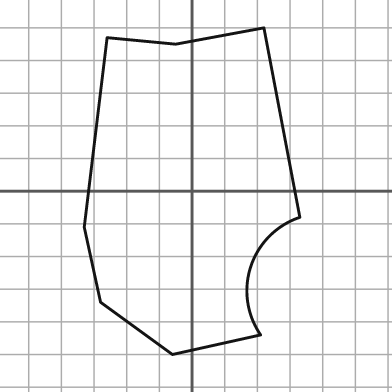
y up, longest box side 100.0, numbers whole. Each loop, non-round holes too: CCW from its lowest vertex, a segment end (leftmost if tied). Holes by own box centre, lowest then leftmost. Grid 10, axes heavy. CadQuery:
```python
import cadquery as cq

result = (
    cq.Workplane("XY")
    .moveTo(-6.0, -50.0)
    .lineTo(21.0, -44.0)
    .threePointArc((18.0, -23.0), (33.0, -8.0))
    .lineTo(22.0, 50.0)
    .lineTo(-5.0, 45.0)
    .lineTo(-26.0, 47.0)
    .lineTo(-33.0, -11.0)
    .lineTo(-28.0, -34.0)
    .close()
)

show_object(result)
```